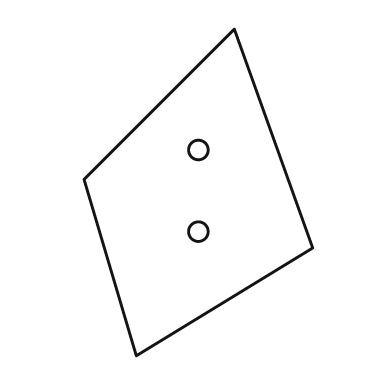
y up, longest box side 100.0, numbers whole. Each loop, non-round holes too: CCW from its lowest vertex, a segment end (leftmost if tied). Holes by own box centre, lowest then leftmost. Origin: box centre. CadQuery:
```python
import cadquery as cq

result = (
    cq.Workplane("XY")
    .moveTo(-19.0, -50.0)
    .lineTo(35.0, -17.0)
    .lineTo(11.0, 50.0)
    .lineTo(-35.0, 4.0)
    .close()
    .moveTo(0.0, -12.0)
    .circle(3.0)
    .moveTo(0.0, 13.0)
    .circle(3.0)
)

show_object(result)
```